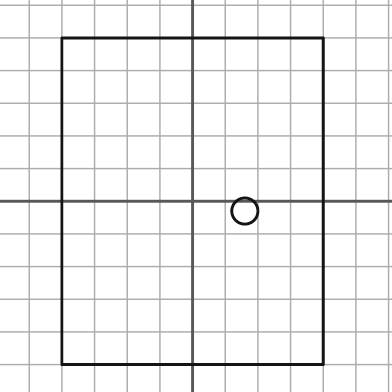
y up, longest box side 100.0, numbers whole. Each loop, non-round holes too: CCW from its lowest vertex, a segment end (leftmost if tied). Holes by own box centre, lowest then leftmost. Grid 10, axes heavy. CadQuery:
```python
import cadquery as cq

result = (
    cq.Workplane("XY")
    .moveTo(-40.0, -50.0)
    .lineTo(40.0, -50.0)
    .lineTo(40.0, 50.0)
    .lineTo(-40.0, 50.0)
    .close()
    .moveTo(16.0, -3.0)
    .circle(4.0)
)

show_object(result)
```